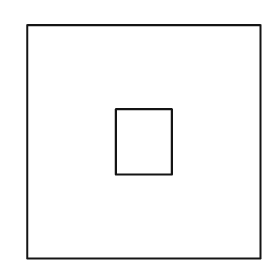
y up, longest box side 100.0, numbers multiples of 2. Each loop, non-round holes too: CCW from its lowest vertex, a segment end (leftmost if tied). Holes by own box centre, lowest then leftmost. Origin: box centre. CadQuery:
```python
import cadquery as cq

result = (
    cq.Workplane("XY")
    .moveTo(-50.0, -50.0)
    .lineTo(50.0, -50.0)
    .lineTo(50.0, 50.0)
    .lineTo(-50.0, 50.0)
    .close()
    .moveTo(-12.0, -14.0)
    .lineTo(12.0, -14.0)
    .lineTo(12.0, 14.0)
    .lineTo(-12.0, 14.0)
    .close()
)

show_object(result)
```